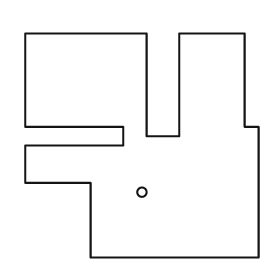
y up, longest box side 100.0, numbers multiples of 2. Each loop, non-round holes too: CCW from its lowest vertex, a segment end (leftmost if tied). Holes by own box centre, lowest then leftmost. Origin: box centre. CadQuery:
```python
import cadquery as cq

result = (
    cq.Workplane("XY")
    .moveTo(-22.0, -48.0)
    .lineTo(50.0, -48.0)
    .lineTo(50.0, 8.0)
    .lineTo(44.0, 8.0)
    .lineTo(44.0, 48.0)
    .lineTo(16.0, 48.0)
    .lineTo(16.0, 4.0)
    .lineTo(2.0, 4.0)
    .lineTo(2.0, 48.0)
    .lineTo(-50.0, 48.0)
    .lineTo(-50.0, 8.0)
    .lineTo(-8.0, 8.0)
    .lineTo(-8.0, 0.0)
    .lineTo(-50.0, 0.0)
    .lineTo(-50.0, -16.0)
    .lineTo(-22.0, -16.0)
    .close()
    .moveTo(0.0, -20.0)
    .circle(2.0)
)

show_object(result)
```